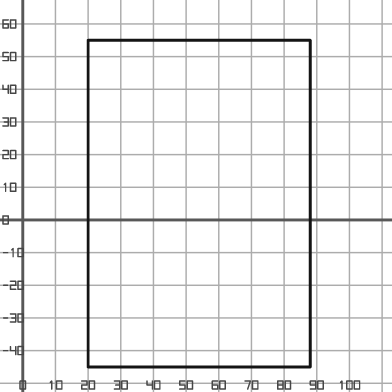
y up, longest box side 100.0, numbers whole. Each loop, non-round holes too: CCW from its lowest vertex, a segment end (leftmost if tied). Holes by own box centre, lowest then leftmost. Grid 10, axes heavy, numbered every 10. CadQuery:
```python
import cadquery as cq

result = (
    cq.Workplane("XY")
    .moveTo(20.0, -45.0)
    .lineTo(88.0, -45.0)
    .lineTo(88.0, 55.0)
    .lineTo(20.0, 55.0)
    .close()
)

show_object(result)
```